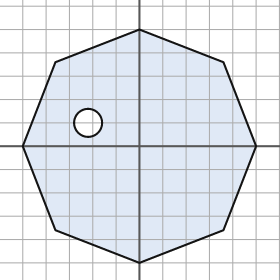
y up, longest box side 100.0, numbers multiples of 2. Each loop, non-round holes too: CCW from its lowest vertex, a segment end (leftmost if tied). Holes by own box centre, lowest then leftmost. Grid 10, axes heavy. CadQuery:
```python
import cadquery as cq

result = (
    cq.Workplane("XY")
    .moveTo(0.0, -50.0)
    .lineTo(36.0, -36.0)
    .lineTo(50.0, 0.0)
    .lineTo(36.0, 36.0)
    .lineTo(0.0, 50.0)
    .lineTo(-36.0, 36.0)
    .lineTo(-50.0, 0.0)
    .lineTo(-36.0, -36.0)
    .close()
    .moveTo(-22.0, 10.0)
    .circle(6.0)
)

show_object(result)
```